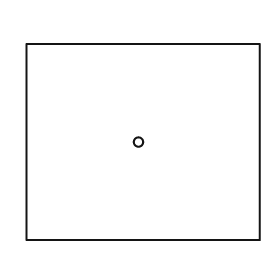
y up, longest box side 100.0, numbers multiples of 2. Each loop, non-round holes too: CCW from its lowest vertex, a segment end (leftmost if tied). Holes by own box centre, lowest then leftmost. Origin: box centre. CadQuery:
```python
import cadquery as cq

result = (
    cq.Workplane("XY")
    .moveTo(-50.0, -42.0)
    .lineTo(50.0, -42.0)
    .lineTo(50.0, 42.0)
    .lineTo(-50.0, 42.0)
    .close()
    .moveTo(-2.0, 0.0)
    .circle(2.0)
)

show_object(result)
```